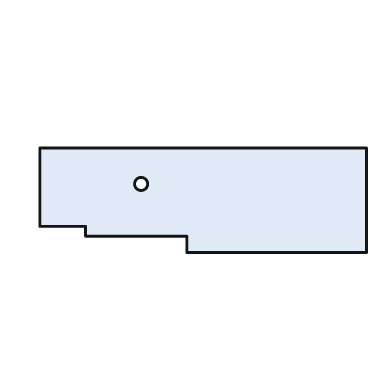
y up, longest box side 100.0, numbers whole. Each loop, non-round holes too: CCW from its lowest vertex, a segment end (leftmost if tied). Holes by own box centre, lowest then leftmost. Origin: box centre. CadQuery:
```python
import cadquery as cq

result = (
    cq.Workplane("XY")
    .moveTo(-5.0, -16.0)
    .lineTo(50.0, -16.0)
    .lineTo(50.0, 16.0)
    .lineTo(-50.0, 16.0)
    .lineTo(-50.0, -8.0)
    .lineTo(-36.0, -8.0)
    .lineTo(-36.0, -11.0)
    .lineTo(-5.0, -11.0)
    .close()
    .moveTo(-19.0, 5.0)
    .circle(2.0)
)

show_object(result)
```